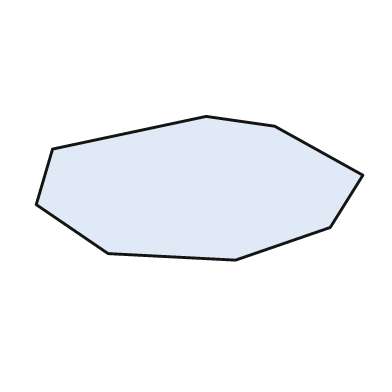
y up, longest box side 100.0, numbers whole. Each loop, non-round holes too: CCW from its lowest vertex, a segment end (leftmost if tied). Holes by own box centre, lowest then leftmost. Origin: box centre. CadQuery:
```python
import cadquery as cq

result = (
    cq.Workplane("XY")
    .moveTo(11.0, -22.0)
    .lineTo(40.0, -12.0)
    .lineTo(50.0, 4.0)
    .lineTo(23.0, 19.0)
    .lineTo(2.0, 22.0)
    .lineTo(-45.0, 12.0)
    .lineTo(-50.0, -5.0)
    .lineTo(-28.0, -20.0)
    .close()
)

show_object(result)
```